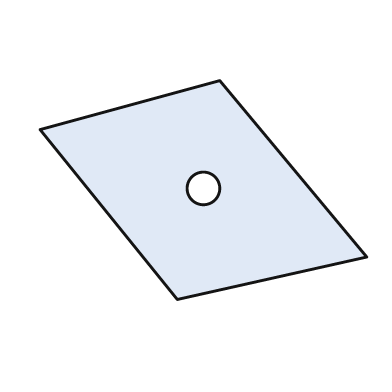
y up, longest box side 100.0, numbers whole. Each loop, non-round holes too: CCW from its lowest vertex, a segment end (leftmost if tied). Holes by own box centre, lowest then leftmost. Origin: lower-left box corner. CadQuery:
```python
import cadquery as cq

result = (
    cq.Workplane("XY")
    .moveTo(42.0, 0.0)
    .lineTo(100.0, 13.0)
    .lineTo(55.0, 67.0)
    .lineTo(0.0, 52.0)
    .close()
    .moveTo(50.0, 34.0)
    .circle(5.0)
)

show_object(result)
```